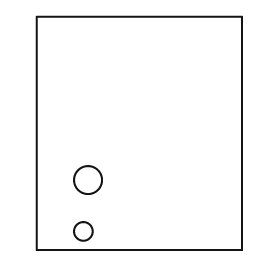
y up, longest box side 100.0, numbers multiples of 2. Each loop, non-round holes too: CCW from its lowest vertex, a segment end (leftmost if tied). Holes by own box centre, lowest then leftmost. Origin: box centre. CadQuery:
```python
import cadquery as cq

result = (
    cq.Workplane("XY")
    .moveTo(-44.0, -50.0)
    .lineTo(44.0, -50.0)
    .lineTo(44.0, 50.0)
    .lineTo(-44.0, 50.0)
    .close()
    .moveTo(-24.0, -42.0)
    .circle(4.0)
    .moveTo(-22.0, -20.0)
    .circle(6.0)
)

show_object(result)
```